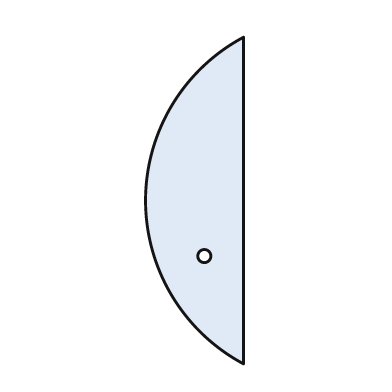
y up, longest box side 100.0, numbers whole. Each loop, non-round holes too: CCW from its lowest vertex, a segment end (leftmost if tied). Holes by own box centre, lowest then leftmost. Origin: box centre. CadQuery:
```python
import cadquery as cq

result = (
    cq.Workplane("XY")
    .moveTo(15.0, -50.0)
    .lineTo(15.0, 50.0)
    .threePointArc((-15.0, 0.0), (15.0, -50.0))
    .close()
    .moveTo(3.0, -17.0)
    .circle(2.0)
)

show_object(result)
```